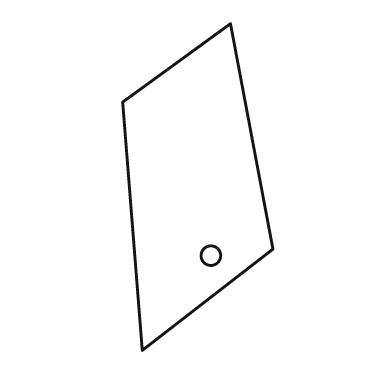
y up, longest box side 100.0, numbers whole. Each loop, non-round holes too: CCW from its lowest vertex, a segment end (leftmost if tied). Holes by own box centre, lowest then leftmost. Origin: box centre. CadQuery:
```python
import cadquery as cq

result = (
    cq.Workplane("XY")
    .moveTo(-17.0, -50.0)
    .lineTo(23.0, -19.0)
    .lineTo(10.0, 50.0)
    .lineTo(-23.0, 26.0)
    .close()
    .moveTo(4.0, -21.0)
    .circle(3.0)
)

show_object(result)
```